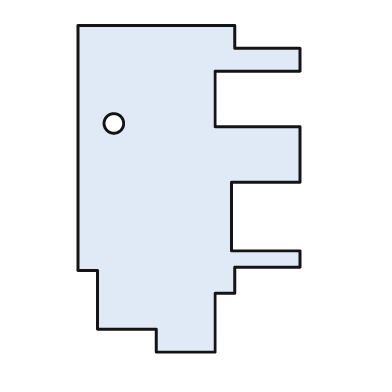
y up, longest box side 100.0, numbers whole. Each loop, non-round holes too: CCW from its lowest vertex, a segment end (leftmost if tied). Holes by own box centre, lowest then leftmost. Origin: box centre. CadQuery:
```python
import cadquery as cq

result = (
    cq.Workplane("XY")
    .moveTo(-10.0, -50.0)
    .lineTo(8.0, -50.0)
    .lineTo(8.0, -32.0)
    .lineTo(14.0, -32.0)
    .lineTo(14.0, -24.0)
    .lineTo(34.0, -24.0)
    .lineTo(34.0, -19.0)
    .lineTo(13.0, -19.0)
    .lineTo(13.0, 2.0)
    .lineTo(34.0, 2.0)
    .lineTo(34.0, 19.0)
    .lineTo(8.0, 19.0)
    .lineTo(8.0, 36.0)
    .lineTo(34.0, 36.0)
    .lineTo(34.0, 43.0)
    .lineTo(14.0, 43.0)
    .lineTo(14.0, 50.0)
    .lineTo(-34.0, 50.0)
    .lineTo(-34.0, -25.0)
    .lineTo(-28.0, -25.0)
    .lineTo(-28.0, -43.0)
    .lineTo(-10.0, -43.0)
    .close()
    .moveTo(-23.0, 20.0)
    .circle(3.0)
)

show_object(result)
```